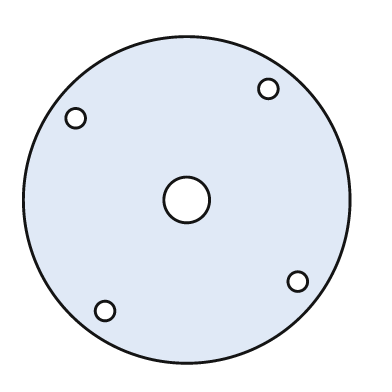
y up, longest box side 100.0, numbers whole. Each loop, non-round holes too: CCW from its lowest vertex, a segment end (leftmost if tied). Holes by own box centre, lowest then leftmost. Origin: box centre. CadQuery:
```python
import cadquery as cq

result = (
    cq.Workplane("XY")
    .moveTo(0.0, 0.0)
    .circle(50.0)
    .moveTo(-25.0, -34.0)
    .circle(3.0)
    .moveTo(34.0, -25.0)
    .circle(3.0)
    .moveTo(0.0, 0.0)
    .circle(7.0)
    .moveTo(-34.0, 25.0)
    .circle(3.0)
    .moveTo(25.0, 34.0)
    .circle(3.0)
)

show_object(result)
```